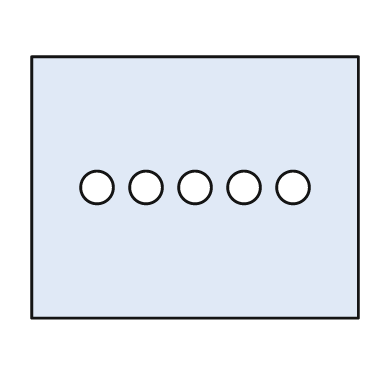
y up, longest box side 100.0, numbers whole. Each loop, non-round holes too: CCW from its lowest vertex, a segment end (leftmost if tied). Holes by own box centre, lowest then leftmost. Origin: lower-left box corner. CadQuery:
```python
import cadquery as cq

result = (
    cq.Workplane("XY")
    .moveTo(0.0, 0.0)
    .lineTo(100.0, 0.0)
    .lineTo(100.0, 80.0)
    .lineTo(0.0, 80.0)
    .close()
    .moveTo(20.0, 40.0)
    .circle(5.0)
    .moveTo(35.0, 40.0)
    .circle(5.0)
    .moveTo(50.0, 40.0)
    .circle(5.0)
    .moveTo(65.0, 40.0)
    .circle(5.0)
    .moveTo(80.0, 40.0)
    .circle(5.0)
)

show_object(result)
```